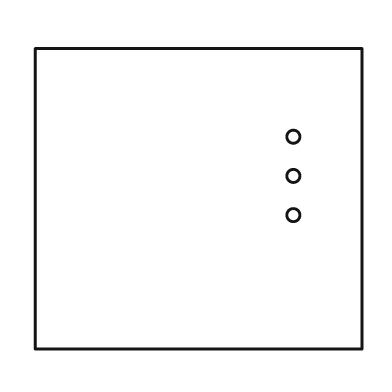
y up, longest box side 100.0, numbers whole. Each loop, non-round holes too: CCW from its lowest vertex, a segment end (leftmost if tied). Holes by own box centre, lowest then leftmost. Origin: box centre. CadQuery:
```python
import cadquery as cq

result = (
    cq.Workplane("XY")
    .moveTo(-50.0, -46.0)
    .lineTo(50.0, -46.0)
    .lineTo(50.0, 46.0)
    .lineTo(-50.0, 46.0)
    .close()
    .moveTo(29.0, -5.0)
    .circle(2.0)
    .moveTo(29.0, 7.0)
    .circle(2.0)
    .moveTo(29.0, 19.0)
    .circle(2.0)
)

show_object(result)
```